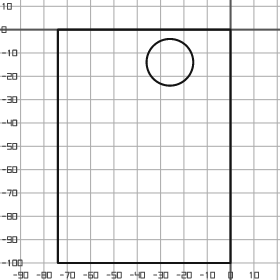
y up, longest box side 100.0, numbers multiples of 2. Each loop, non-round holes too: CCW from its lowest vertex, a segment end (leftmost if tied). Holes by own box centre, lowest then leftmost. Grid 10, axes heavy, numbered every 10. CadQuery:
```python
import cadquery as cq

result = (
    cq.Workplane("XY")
    .moveTo(-74.0, -100.0)
    .lineTo(0.0, -100.0)
    .lineTo(0.0, 0.0)
    .lineTo(-74.0, 0.0)
    .close()
    .moveTo(-26.0, -14.0)
    .circle(10.0)
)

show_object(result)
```